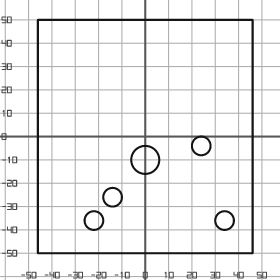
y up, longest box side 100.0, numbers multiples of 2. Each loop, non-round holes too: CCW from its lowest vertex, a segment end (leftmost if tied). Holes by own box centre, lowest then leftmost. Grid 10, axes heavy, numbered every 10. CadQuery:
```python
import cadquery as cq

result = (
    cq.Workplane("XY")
    .moveTo(-46.0, -50.0)
    .lineTo(46.0, -50.0)
    .lineTo(46.0, 50.0)
    .lineTo(-46.0, 50.0)
    .close()
    .moveTo(-22.0, -36.0)
    .circle(4.0)
    .moveTo(34.0, -36.0)
    .circle(4.0)
    .moveTo(-14.0, -26.0)
    .circle(4.0)
    .moveTo(0.0, -10.0)
    .circle(6.0)
    .moveTo(24.0, -4.0)
    .circle(4.0)
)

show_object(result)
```